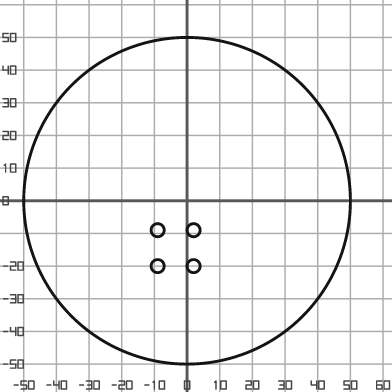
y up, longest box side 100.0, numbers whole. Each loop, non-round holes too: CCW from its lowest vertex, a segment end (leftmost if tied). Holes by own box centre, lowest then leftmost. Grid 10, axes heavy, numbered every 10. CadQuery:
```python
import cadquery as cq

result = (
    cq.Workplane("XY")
    .moveTo(0.0, 0.0)
    .circle(50.0)
    .moveTo(-9.0, -20.0)
    .circle(2.0)
    .moveTo(2.0, -20.0)
    .circle(2.0)
    .moveTo(-9.0, -9.0)
    .circle(2.0)
    .moveTo(2.0, -9.0)
    .circle(2.0)
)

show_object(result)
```